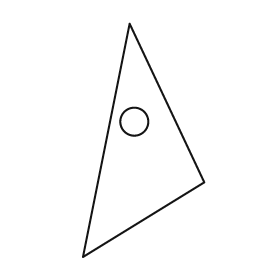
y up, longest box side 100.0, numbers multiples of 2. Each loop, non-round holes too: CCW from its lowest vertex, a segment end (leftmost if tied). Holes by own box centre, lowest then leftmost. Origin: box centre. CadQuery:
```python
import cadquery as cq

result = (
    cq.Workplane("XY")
    .moveTo(-26.0, -50.0)
    .lineTo(26.0, -18.0)
    .lineTo(-6.0, 50.0)
    .close()
    .moveTo(-4.0, 8.0)
    .circle(6.0)
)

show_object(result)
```